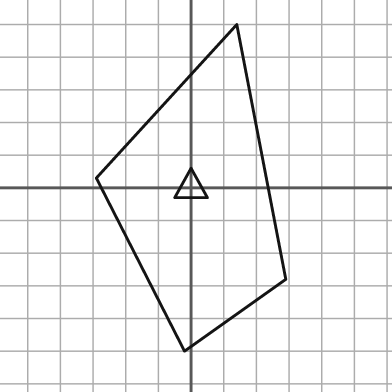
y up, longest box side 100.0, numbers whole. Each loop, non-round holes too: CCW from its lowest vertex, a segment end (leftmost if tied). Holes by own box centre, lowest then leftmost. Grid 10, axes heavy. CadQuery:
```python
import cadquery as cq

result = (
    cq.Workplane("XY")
    .moveTo(-2.0, -50.0)
    .lineTo(29.0, -28.0)
    .lineTo(14.0, 50.0)
    .lineTo(-29.0, 3.0)
    .close()
    .moveTo(-5.0, -3.0)
    .lineTo(5.0, -3.0)
    .lineTo(0.0, 6.0)
    .close()
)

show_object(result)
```